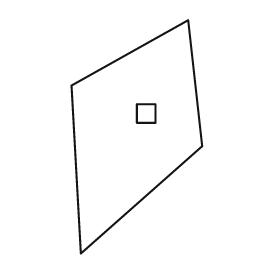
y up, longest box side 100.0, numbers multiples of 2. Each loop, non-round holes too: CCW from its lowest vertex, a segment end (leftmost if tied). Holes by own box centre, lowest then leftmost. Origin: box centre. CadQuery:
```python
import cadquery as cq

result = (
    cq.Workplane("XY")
    .moveTo(-24.0, -50.0)
    .lineTo(28.0, -4.0)
    .lineTo(22.0, 50.0)
    .lineTo(-28.0, 22.0)
    .close()
    .moveTo(0.0, 6.0)
    .lineTo(8.0, 6.0)
    .lineTo(8.0, 14.0)
    .lineTo(0.0, 14.0)
    .close()
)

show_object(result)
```